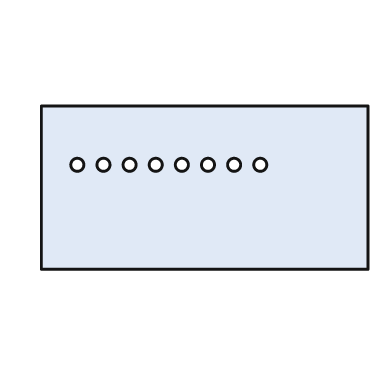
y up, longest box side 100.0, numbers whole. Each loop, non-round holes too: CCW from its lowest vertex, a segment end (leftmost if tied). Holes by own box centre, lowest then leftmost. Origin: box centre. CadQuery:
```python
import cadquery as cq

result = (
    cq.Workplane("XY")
    .moveTo(-50.0, -25.0)
    .lineTo(50.0, -25.0)
    .lineTo(50.0, 25.0)
    .lineTo(-50.0, 25.0)
    .close()
    .moveTo(-39.0, 7.0)
    .circle(2.0)
    .moveTo(-31.0, 7.0)
    .circle(2.0)
    .moveTo(-23.0, 7.0)
    .circle(2.0)
    .moveTo(-15.0, 7.0)
    .circle(2.0)
    .moveTo(-7.0, 7.0)
    .circle(2.0)
    .moveTo(1.0, 7.0)
    .circle(2.0)
    .moveTo(9.0, 7.0)
    .circle(2.0)
    .moveTo(17.0, 7.0)
    .circle(2.0)
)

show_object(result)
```